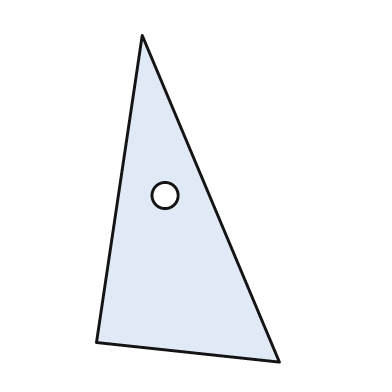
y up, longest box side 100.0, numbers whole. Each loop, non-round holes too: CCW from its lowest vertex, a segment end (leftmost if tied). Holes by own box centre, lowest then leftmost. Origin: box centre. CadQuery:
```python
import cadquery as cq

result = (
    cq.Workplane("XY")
    .moveTo(28.0, -50.0)
    .lineTo(-14.0, 50.0)
    .lineTo(-28.0, -44.0)
    .close()
    .moveTo(-7.0, 1.0)
    .circle(4.0)
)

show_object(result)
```